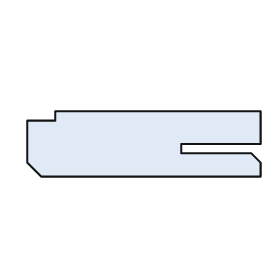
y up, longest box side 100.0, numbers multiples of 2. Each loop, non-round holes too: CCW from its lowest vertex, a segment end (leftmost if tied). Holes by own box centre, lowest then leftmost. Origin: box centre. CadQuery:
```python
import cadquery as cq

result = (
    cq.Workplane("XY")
    .moveTo(-44.0, -14.0)
    .lineTo(50.0, -14.0)
    .lineTo(50.0, -8.0)
    .lineTo(46.0, -4.0)
    .lineTo(16.0, -4.0)
    .lineTo(16.0, 0.0)
    .lineTo(50.0, 0.0)
    .lineTo(50.0, 14.0)
    .lineTo(-38.0, 14.0)
    .lineTo(-38.0, 10.0)
    .lineTo(-50.0, 10.0)
    .lineTo(-50.0, -8.0)
    .close()
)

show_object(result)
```